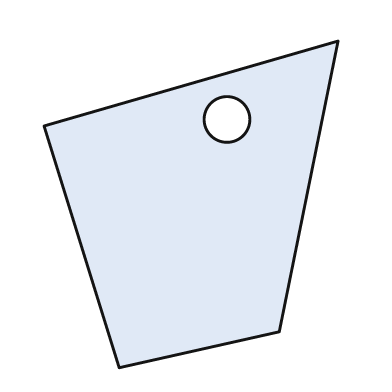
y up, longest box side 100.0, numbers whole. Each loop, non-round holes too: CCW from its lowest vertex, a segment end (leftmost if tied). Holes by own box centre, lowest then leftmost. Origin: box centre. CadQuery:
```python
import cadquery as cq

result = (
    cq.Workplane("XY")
    .moveTo(-22.0, -50.0)
    .lineTo(27.0, -39.0)
    .lineTo(45.0, 50.0)
    .lineTo(-45.0, 24.0)
    .close()
    .moveTo(11.0, 26.0)
    .circle(7.0)
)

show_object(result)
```